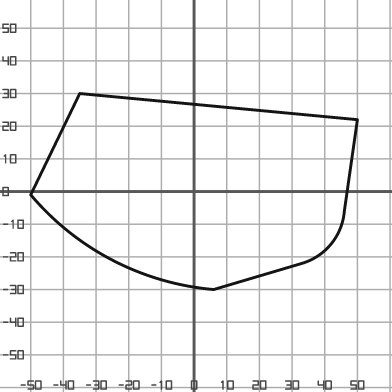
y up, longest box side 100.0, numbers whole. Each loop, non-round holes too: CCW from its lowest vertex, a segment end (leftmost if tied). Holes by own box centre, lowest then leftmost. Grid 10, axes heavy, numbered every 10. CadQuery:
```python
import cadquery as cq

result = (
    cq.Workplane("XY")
    .moveTo(6.0, -30.0)
    .lineTo(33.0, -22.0)
    .threePointArc((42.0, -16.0), (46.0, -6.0))
    .lineTo(50.0, 22.0)
    .lineTo(-35.0, 30.0)
    .lineTo(-50.0, -1.0)
    .threePointArc((-25.0, -21.0), (6.0, -30.0))
    .close()
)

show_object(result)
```